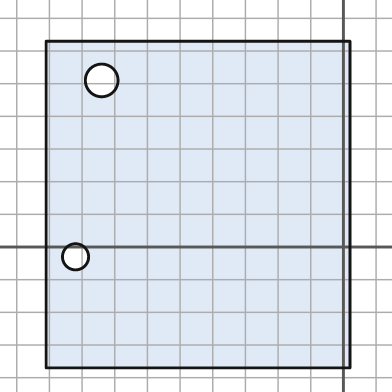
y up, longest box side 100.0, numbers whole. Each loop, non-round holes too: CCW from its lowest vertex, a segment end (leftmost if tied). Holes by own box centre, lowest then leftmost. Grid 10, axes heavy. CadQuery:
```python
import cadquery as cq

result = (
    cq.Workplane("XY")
    .moveTo(-91.0, -37.0)
    .lineTo(2.0, -37.0)
    .lineTo(2.0, 63.0)
    .lineTo(-91.0, 63.0)
    .close()
    .moveTo(-82.0, -3.0)
    .circle(4.0)
    .moveTo(-74.0, 51.0)
    .circle(5.0)
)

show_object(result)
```